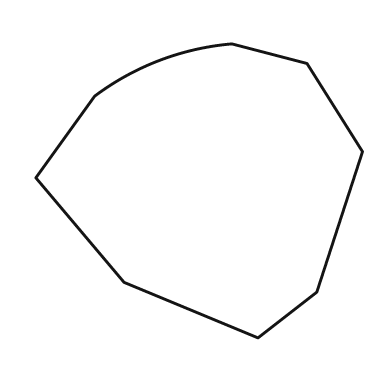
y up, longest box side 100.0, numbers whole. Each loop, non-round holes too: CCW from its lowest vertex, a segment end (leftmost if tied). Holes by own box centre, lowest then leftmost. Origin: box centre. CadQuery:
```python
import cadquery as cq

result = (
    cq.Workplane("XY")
    .moveTo(18.0, -45.0)
    .lineTo(36.0, -31.0)
    .lineTo(50.0, 12.0)
    .lineTo(33.0, 39.0)
    .lineTo(10.0, 45.0)
    .threePointArc((-12.0, 40.0), (-32.0, 29.0))
    .lineTo(-50.0, 4.0)
    .lineTo(-23.0, -28.0)
    .close()
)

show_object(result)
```